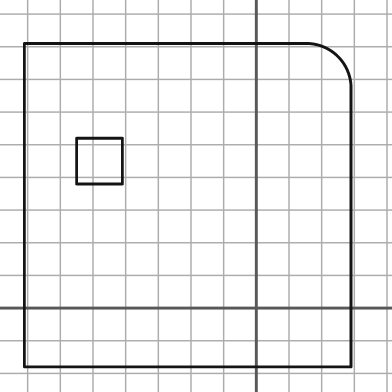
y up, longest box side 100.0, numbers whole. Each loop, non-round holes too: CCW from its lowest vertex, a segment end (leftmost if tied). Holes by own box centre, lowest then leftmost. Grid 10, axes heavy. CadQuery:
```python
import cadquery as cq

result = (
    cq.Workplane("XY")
    .moveTo(-71.0, -18.0)
    .lineTo(29.0, -18.0)
    .lineTo(29.0, 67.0)
    .threePointArc((25.0, 77.0), (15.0, 81.0))
    .lineTo(-71.0, 81.0)
    .close()
    .moveTo(-55.0, 38.0)
    .lineTo(-41.0, 38.0)
    .lineTo(-41.0, 52.0)
    .lineTo(-55.0, 52.0)
    .close()
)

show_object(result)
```